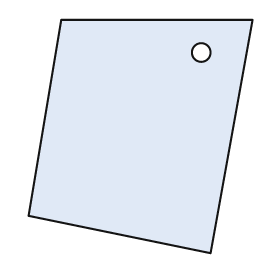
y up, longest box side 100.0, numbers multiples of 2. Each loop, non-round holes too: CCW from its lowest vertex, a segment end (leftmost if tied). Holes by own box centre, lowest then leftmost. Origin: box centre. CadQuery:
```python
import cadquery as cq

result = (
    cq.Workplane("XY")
    .moveTo(30.0, -50.0)
    .lineTo(48.0, 50.0)
    .lineTo(-34.0, 50.0)
    .lineTo(-48.0, -34.0)
    .close()
    .moveTo(26.0, 36.0)
    .circle(4.0)
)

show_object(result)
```